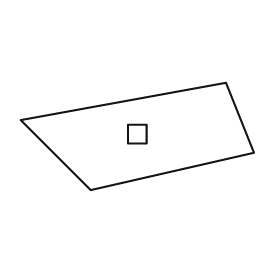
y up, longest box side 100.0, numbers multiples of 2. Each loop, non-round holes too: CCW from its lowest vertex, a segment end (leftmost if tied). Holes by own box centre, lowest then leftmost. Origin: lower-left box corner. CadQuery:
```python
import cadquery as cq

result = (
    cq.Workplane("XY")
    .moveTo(30.0, 0.0)
    .lineTo(100.0, 16.0)
    .lineTo(88.0, 46.0)
    .lineTo(0.0, 30.0)
    .close()
    .moveTo(46.0, 20.0)
    .lineTo(54.0, 20.0)
    .lineTo(54.0, 28.0)
    .lineTo(46.0, 28.0)
    .close()
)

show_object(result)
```